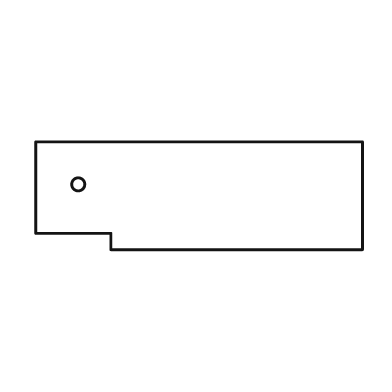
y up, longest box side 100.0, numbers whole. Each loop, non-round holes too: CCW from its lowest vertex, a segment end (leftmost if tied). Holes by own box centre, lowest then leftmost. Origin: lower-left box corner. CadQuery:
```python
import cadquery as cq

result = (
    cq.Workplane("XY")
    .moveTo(23.0, 0.0)
    .lineTo(100.0, 0.0)
    .lineTo(100.0, 33.0)
    .lineTo(0.0, 33.0)
    .lineTo(0.0, 5.0)
    .lineTo(23.0, 5.0)
    .close()
    .moveTo(13.0, 20.0)
    .circle(2.0)
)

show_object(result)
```